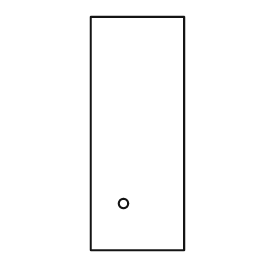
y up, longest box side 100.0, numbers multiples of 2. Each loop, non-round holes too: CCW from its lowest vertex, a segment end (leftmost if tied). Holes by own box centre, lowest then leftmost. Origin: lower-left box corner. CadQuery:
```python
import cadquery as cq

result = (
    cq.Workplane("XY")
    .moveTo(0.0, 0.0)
    .lineTo(40.0, 0.0)
    .lineTo(40.0, 100.0)
    .lineTo(0.0, 100.0)
    .close()
    .moveTo(14.0, 20.0)
    .circle(2.0)
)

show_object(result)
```